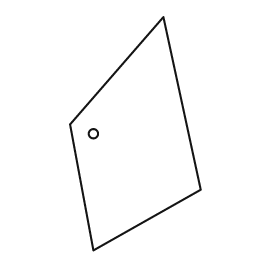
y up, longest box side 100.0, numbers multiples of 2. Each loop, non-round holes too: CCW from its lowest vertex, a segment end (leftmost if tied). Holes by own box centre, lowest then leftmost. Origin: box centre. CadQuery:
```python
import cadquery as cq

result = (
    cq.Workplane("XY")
    .moveTo(-18.0, -50.0)
    .lineTo(28.0, -24.0)
    .lineTo(12.0, 50.0)
    .lineTo(-28.0, 4.0)
    .close()
    .moveTo(-18.0, 0.0)
    .circle(2.0)
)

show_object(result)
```